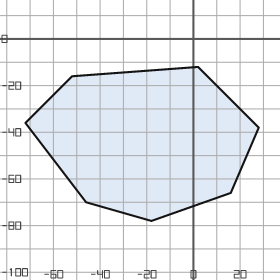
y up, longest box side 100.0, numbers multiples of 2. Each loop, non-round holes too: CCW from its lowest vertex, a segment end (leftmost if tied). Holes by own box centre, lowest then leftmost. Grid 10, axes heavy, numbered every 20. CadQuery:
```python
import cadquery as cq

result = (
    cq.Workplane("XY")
    .moveTo(-18.0, -78.0)
    .lineTo(16.0, -66.0)
    .lineTo(28.0, -38.0)
    .lineTo(2.0, -12.0)
    .lineTo(-52.0, -16.0)
    .lineTo(-72.0, -36.0)
    .lineTo(-46.0, -70.0)
    .close()
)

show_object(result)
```